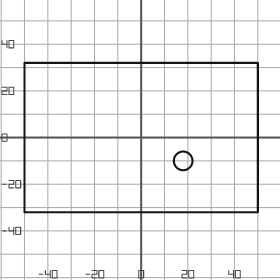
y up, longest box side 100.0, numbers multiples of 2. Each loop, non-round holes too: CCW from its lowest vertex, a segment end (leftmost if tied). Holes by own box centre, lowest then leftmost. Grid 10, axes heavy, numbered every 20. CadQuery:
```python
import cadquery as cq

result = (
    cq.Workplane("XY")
    .moveTo(-50.0, -32.0)
    .lineTo(50.0, -32.0)
    .lineTo(50.0, 32.0)
    .lineTo(-50.0, 32.0)
    .close()
    .moveTo(18.0, -10.0)
    .circle(4.0)
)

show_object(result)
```